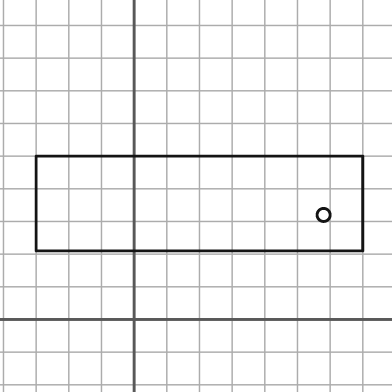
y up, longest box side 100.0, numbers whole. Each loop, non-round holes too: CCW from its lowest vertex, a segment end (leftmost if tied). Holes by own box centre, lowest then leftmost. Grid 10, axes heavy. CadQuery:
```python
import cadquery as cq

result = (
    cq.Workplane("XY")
    .moveTo(-30.0, 21.0)
    .lineTo(70.0, 21.0)
    .lineTo(70.0, 50.0)
    .lineTo(-30.0, 50.0)
    .close()
    .moveTo(58.0, 32.0)
    .circle(2.0)
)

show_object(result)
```